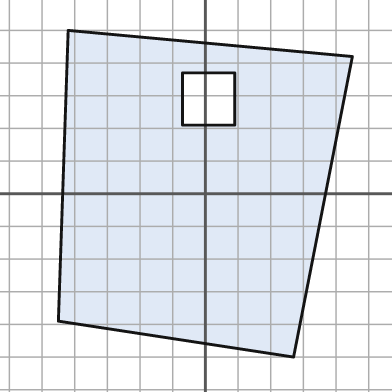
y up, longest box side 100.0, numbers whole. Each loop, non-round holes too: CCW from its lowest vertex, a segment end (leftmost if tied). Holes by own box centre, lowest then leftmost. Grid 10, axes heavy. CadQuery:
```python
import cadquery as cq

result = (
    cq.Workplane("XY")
    .moveTo(27.0, -50.0)
    .lineTo(45.0, 42.0)
    .lineTo(-42.0, 50.0)
    .lineTo(-45.0, -39.0)
    .close()
    .moveTo(-7.0, 21.0)
    .lineTo(9.0, 21.0)
    .lineTo(9.0, 37.0)
    .lineTo(-7.0, 37.0)
    .close()
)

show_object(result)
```